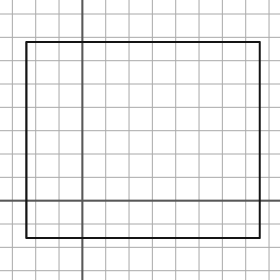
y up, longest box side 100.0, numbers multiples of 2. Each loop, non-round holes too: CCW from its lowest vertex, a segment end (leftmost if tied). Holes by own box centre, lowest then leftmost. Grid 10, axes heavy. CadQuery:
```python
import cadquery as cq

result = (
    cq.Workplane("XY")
    .moveTo(-24.0, -16.0)
    .lineTo(76.0, -16.0)
    .lineTo(76.0, 68.0)
    .lineTo(-24.0, 68.0)
    .close()
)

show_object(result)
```